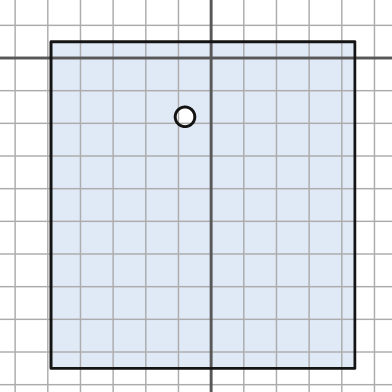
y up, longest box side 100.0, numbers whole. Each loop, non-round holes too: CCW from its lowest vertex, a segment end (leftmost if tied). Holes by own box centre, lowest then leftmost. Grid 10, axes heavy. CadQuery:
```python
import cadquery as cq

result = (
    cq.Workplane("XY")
    .moveTo(-49.0, -95.0)
    .lineTo(44.0, -95.0)
    .lineTo(44.0, 5.0)
    .lineTo(-49.0, 5.0)
    .close()
    .moveTo(-8.0, -18.0)
    .circle(3.0)
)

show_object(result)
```